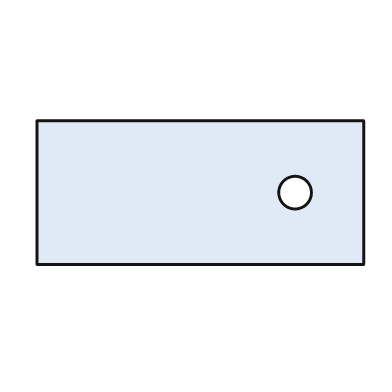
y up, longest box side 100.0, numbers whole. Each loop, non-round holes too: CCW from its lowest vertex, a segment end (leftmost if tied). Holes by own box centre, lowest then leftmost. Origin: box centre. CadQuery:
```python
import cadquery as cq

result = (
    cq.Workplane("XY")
    .moveTo(-50.0, -22.0)
    .lineTo(50.0, -22.0)
    .lineTo(50.0, 22.0)
    .lineTo(-50.0, 22.0)
    .close()
    .moveTo(29.0, 0.0)
    .circle(5.0)
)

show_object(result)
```